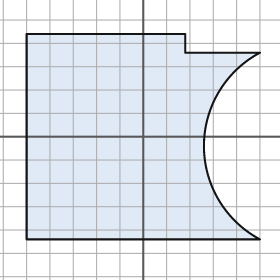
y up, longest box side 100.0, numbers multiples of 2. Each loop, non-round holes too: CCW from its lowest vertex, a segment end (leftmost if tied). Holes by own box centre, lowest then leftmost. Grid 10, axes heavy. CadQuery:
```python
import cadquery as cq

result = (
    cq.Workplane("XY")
    .moveTo(-50.0, -44.0)
    .lineTo(50.0, -44.0)
    .threePointArc((26.0, -4.0), (50.0, 36.0))
    .lineTo(18.0, 36.0)
    .lineTo(18.0, 44.0)
    .lineTo(-50.0, 44.0)
    .close()
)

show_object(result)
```